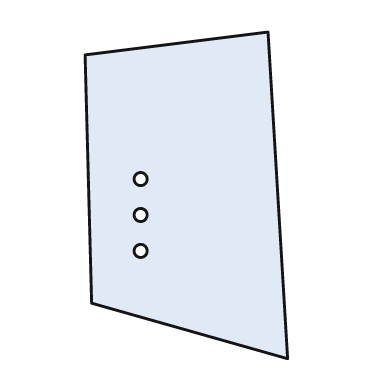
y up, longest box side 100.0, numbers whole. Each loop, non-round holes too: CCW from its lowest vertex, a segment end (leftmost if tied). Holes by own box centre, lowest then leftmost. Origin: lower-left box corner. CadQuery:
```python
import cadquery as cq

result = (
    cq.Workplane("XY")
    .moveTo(62.0, 0.0)
    .lineTo(56.0, 100.0)
    .lineTo(0.0, 93.0)
    .lineTo(2.0, 17.0)
    .close()
    .moveTo(17.0, 33.0)
    .circle(2.0)
    .moveTo(17.0, 44.0)
    .circle(2.0)
    .moveTo(17.0, 55.0)
    .circle(2.0)
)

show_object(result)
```